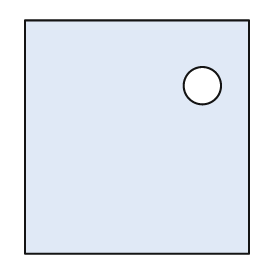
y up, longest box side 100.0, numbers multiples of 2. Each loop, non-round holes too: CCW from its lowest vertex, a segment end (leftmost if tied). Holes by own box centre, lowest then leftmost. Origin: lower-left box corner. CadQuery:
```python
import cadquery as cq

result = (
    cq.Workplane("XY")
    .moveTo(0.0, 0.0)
    .lineTo(96.0, 0.0)
    .lineTo(96.0, 100.0)
    .lineTo(0.0, 100.0)
    .close()
    .moveTo(76.0, 72.0)
    .circle(8.0)
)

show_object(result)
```